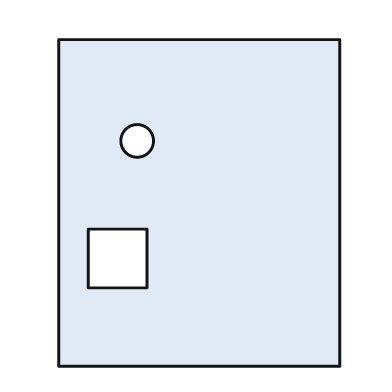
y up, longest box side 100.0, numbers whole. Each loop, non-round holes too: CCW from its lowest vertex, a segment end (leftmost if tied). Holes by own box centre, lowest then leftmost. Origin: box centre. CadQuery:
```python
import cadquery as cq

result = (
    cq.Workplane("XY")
    .moveTo(-43.0, -50.0)
    .lineTo(43.0, -50.0)
    .lineTo(43.0, 50.0)
    .lineTo(-43.0, 50.0)
    .close()
    .moveTo(-34.0, -26.0)
    .lineTo(-16.0, -26.0)
    .lineTo(-16.0, -8.0)
    .lineTo(-34.0, -8.0)
    .close()
    .moveTo(-19.0, 19.0)
    .circle(5.0)
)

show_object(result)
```